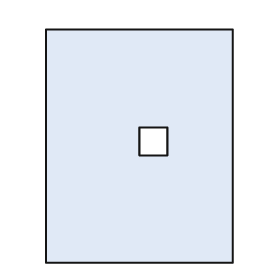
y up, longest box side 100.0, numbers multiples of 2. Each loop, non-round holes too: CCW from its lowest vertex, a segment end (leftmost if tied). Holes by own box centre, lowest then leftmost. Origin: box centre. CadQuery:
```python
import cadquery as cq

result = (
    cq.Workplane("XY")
    .moveTo(-40.0, -50.0)
    .lineTo(40.0, -50.0)
    .lineTo(40.0, 50.0)
    .lineTo(-40.0, 50.0)
    .close()
    .moveTo(0.0, -4.0)
    .lineTo(12.0, -4.0)
    .lineTo(12.0, 8.0)
    .lineTo(0.0, 8.0)
    .close()
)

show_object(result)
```